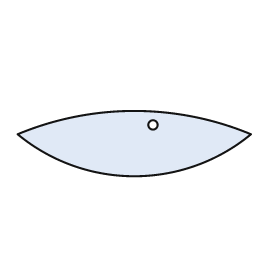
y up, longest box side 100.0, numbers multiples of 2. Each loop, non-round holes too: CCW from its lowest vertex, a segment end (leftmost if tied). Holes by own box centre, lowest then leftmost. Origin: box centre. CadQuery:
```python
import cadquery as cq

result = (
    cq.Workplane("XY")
    .moveTo(-50.0, 4.0)
    .threePointArc((0.0, -14.0), (50.0, 4.0))
    .threePointArc((0.0, 14.0), (-50.0, 4.0))
    .close()
    .moveTo(8.0, 8.0)
    .circle(2.0)
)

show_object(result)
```